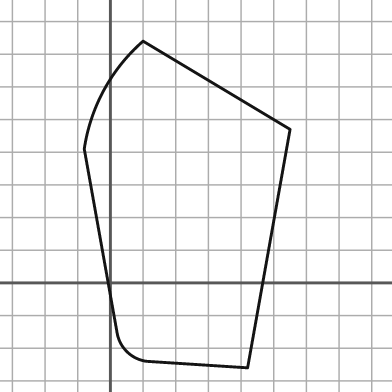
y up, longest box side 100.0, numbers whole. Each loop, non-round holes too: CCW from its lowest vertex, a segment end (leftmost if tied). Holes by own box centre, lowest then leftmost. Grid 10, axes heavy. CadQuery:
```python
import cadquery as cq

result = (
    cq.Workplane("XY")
    .moveTo(42.0, -26.0)
    .lineTo(55.0, 47.0)
    .lineTo(10.0, 74.0)
    .threePointArc((-2.0, 59.0), (-8.0, 41.0))
    .lineTo(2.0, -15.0)
    .threePointArc((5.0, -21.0), (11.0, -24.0))
    .close()
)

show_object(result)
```